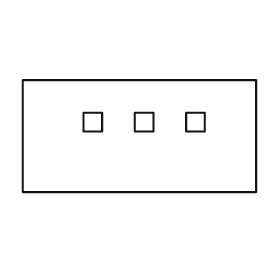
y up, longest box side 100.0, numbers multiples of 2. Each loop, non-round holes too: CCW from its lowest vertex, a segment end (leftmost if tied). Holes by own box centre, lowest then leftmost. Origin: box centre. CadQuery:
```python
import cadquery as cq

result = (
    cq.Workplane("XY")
    .moveTo(-50.0, -24.0)
    .lineTo(50.0, -24.0)
    .lineTo(50.0, 24.0)
    .lineTo(-50.0, 24.0)
    .close()
    .moveTo(-24.0, 2.0)
    .lineTo(-16.0, 2.0)
    .lineTo(-16.0, 10.0)
    .lineTo(-24.0, 10.0)
    .close()
    .moveTo(-2.0, 2.0)
    .lineTo(6.0, 2.0)
    .lineTo(6.0, 10.0)
    .lineTo(-2.0, 10.0)
    .close()
    .moveTo(20.0, 2.0)
    .lineTo(28.0, 2.0)
    .lineTo(28.0, 10.0)
    .lineTo(20.0, 10.0)
    .close()
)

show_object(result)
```